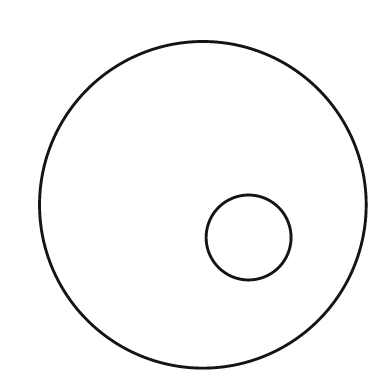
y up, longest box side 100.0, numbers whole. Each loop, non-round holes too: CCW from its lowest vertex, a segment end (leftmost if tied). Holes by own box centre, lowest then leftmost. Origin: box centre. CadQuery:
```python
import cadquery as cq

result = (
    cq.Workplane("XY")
    .moveTo(0.0, 0.0)
    .circle(50.0)
    .moveTo(14.0, -10.0)
    .circle(13.0)
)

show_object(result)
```